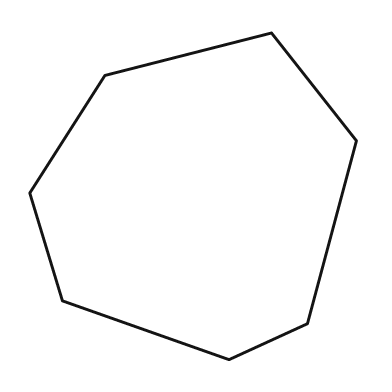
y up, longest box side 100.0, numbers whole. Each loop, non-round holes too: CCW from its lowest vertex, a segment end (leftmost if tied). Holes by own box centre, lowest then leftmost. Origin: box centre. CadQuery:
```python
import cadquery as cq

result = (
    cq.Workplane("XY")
    .moveTo(11.0, -50.0)
    .lineTo(35.0, -39.0)
    .lineTo(50.0, 17.0)
    .lineTo(24.0, 50.0)
    .lineTo(-27.0, 37.0)
    .lineTo(-50.0, 1.0)
    .lineTo(-40.0, -32.0)
    .close()
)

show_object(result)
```